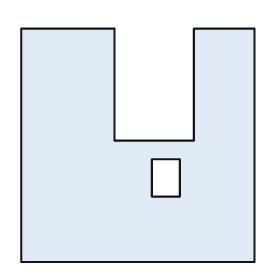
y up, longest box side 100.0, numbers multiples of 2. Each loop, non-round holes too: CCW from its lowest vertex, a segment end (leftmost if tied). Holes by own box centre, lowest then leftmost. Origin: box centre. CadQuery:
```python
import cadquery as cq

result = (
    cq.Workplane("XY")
    .moveTo(-50.0, -50.0)
    .lineTo(50.0, -50.0)
    .lineTo(50.0, 50.0)
    .lineTo(24.0, 50.0)
    .lineTo(24.0, 2.0)
    .lineTo(-10.0, 2.0)
    .lineTo(-10.0, 50.0)
    .lineTo(-50.0, 50.0)
    .close()
    .moveTo(6.0, -22.0)
    .lineTo(18.0, -22.0)
    .lineTo(18.0, -6.0)
    .lineTo(6.0, -6.0)
    .close()
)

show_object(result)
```